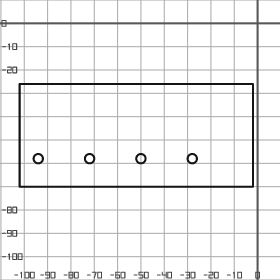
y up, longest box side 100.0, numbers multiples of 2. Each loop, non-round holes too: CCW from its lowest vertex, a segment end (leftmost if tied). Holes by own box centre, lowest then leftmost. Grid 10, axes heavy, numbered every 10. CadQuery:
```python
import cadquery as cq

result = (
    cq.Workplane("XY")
    .moveTo(-102.0, -70.0)
    .lineTo(-2.0, -70.0)
    .lineTo(-2.0, -26.0)
    .lineTo(-102.0, -26.0)
    .close()
    .moveTo(-94.0, -58.0)
    .circle(2.0)
    .moveTo(-72.0, -58.0)
    .circle(2.0)
    .moveTo(-50.0, -58.0)
    .circle(2.0)
    .moveTo(-28.0, -58.0)
    .circle(2.0)
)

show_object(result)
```